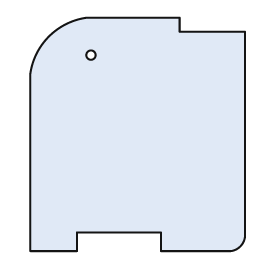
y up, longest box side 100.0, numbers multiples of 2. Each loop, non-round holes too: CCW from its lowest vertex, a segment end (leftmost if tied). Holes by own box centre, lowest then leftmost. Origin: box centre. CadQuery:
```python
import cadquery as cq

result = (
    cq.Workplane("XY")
    .moveTo(-46.0, -50.0)
    .lineTo(-26.0, -50.0)
    .lineTo(-26.0, -42.0)
    .lineTo(10.0, -42.0)
    .lineTo(10.0, -50.0)
    .lineTo(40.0, -50.0)
    .threePointArc((44.0, -48.0), (46.0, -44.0))
    .lineTo(46.0, 44.0)
    .lineTo(18.0, 44.0)
    .lineTo(18.0, 50.0)
    .lineTo(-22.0, 50.0)
    .threePointArc((-38.0, 42.0), (-46.0, 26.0))
    .close()
    .moveTo(-20.0, 34.0)
    .circle(2.0)
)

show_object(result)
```